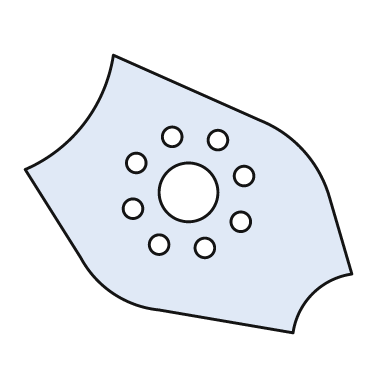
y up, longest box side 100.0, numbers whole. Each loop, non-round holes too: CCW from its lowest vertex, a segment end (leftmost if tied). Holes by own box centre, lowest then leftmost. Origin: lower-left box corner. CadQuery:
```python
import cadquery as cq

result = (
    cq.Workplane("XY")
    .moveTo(82.0, 0.0)
    .threePointArc((88.0, 12.0), (100.0, 18.0))
    .lineTo(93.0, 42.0)
    .threePointArc((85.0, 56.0), (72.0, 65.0))
    .lineTo(27.0, 85.0)
    .threePointArc((18.0, 64.0), (0.0, 50.0))
    .lineTo(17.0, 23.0)
    .threePointArc((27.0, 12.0), (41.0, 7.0))
    .close()
    .moveTo(55.0, 26.0)
    .circle(3.0)
    .moveTo(41.0, 27.0)
    .circle(3.0)
    .moveTo(66.0, 34.0)
    .circle(3.0)
    .moveTo(33.0, 38.0)
    .circle(3.0)
    .moveTo(50.0, 43.0)
    .circle(9.0)
    .moveTo(67.0, 48.0)
    .circle(3.0)
    .moveTo(34.0, 52.0)
    .circle(3.0)
    .moveTo(59.0, 59.0)
    .circle(3.0)
    .moveTo(45.0, 60.0)
    .circle(3.0)
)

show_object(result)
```